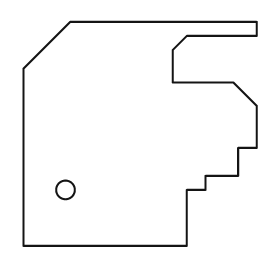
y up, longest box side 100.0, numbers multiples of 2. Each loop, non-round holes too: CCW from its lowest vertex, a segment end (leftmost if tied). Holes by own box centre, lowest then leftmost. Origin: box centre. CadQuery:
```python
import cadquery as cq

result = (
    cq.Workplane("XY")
    .moveTo(-50.0, -48.0)
    .lineTo(20.0, -48.0)
    .lineTo(20.0, -24.0)
    .lineTo(28.0, -24.0)
    .lineTo(28.0, -18.0)
    .lineTo(42.0, -18.0)
    .lineTo(42.0, -6.0)
    .lineTo(50.0, -6.0)
    .lineTo(50.0, 12.0)
    .lineTo(40.0, 22.0)
    .lineTo(14.0, 22.0)
    .lineTo(14.0, 36.0)
    .lineTo(20.0, 42.0)
    .lineTo(50.0, 42.0)
    .lineTo(50.0, 48.0)
    .lineTo(-30.0, 48.0)
    .lineTo(-50.0, 28.0)
    .close()
    .moveTo(-32.0, -24.0)
    .circle(4.0)
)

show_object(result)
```